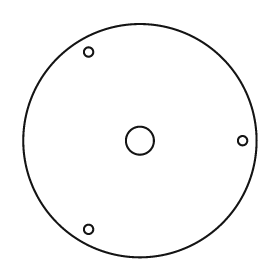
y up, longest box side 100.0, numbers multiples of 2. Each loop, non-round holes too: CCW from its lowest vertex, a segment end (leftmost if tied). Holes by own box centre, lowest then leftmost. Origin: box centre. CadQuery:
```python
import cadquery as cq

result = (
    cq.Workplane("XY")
    .moveTo(0.0, 0.0)
    .circle(50.0)
    .moveTo(-22.0, -38.0)
    .circle(2.0)
    .moveTo(0.0, 0.0)
    .circle(6.0)
    .moveTo(44.0, 0.0)
    .circle(2.0)
    .moveTo(-22.0, 38.0)
    .circle(2.0)
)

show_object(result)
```